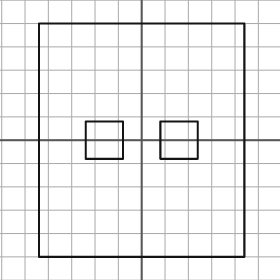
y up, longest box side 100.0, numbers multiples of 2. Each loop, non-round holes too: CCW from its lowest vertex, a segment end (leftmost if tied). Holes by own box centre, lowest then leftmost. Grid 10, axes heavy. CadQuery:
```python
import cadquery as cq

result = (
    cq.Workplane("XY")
    .moveTo(-44.0, -50.0)
    .lineTo(44.0, -50.0)
    .lineTo(44.0, 50.0)
    .lineTo(-44.0, 50.0)
    .close()
    .moveTo(-24.0, -8.0)
    .lineTo(-8.0, -8.0)
    .lineTo(-8.0, 8.0)
    .lineTo(-24.0, 8.0)
    .close()
    .moveTo(8.0, -8.0)
    .lineTo(24.0, -8.0)
    .lineTo(24.0, 8.0)
    .lineTo(8.0, 8.0)
    .close()
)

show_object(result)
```